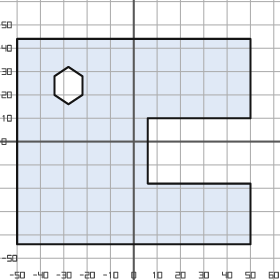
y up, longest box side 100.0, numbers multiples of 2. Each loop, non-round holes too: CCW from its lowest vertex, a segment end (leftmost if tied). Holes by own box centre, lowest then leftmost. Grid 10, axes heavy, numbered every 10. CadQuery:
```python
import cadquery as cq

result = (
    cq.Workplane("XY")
    .moveTo(-50.0, -44.0)
    .lineTo(50.0, -44.0)
    .lineTo(50.0, -18.0)
    .lineTo(6.0, -18.0)
    .lineTo(6.0, 10.0)
    .lineTo(50.0, 10.0)
    .lineTo(50.0, 44.0)
    .lineTo(-50.0, 44.0)
    .close()
    .moveTo(-28.0, 16.0)
    .lineTo(-22.0, 20.0)
    .lineTo(-22.0, 28.0)
    .lineTo(-28.0, 32.0)
    .lineTo(-34.0, 28.0)
    .lineTo(-34.0, 20.0)
    .close()
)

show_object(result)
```